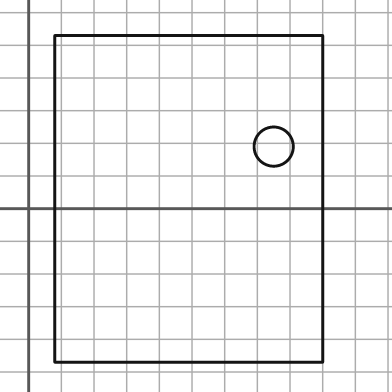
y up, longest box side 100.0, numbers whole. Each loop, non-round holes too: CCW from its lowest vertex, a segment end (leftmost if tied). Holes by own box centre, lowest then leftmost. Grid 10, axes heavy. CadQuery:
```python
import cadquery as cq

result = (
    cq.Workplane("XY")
    .moveTo(8.0, -47.0)
    .lineTo(90.0, -47.0)
    .lineTo(90.0, 53.0)
    .lineTo(8.0, 53.0)
    .close()
    .moveTo(75.0, 19.0)
    .circle(6.0)
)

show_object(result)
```